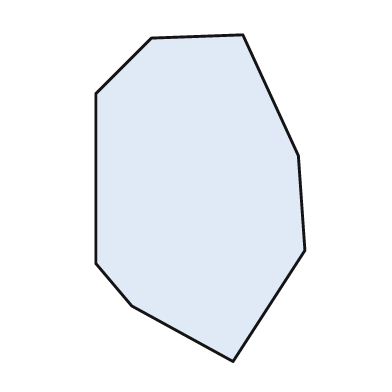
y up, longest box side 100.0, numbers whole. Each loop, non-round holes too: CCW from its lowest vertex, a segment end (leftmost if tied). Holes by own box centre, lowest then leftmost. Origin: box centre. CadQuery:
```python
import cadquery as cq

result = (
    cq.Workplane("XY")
    .moveTo(10.0, -50.0)
    .lineTo(32.0, -16.0)
    .lineTo(30.0, 13.0)
    .lineTo(13.0, 50.0)
    .lineTo(-15.0, 49.0)
    .lineTo(-32.0, 32.0)
    .lineTo(-32.0, -20.0)
    .lineTo(-21.0, -33.0)
    .close()
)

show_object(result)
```